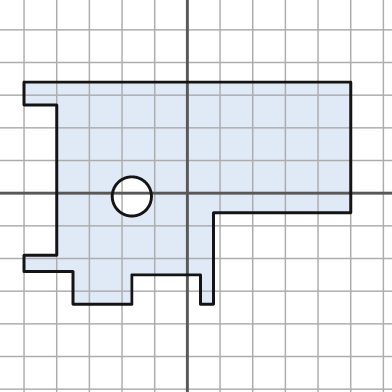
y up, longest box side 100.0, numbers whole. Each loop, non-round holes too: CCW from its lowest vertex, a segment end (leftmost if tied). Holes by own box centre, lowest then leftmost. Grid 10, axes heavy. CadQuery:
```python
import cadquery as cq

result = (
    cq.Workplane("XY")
    .moveTo(-35.0, -34.0)
    .lineTo(-17.0, -34.0)
    .lineTo(-17.0, -25.0)
    .lineTo(4.0, -25.0)
    .lineTo(4.0, -34.0)
    .lineTo(8.0, -34.0)
    .lineTo(8.0, -6.0)
    .lineTo(50.0, -6.0)
    .lineTo(50.0, 34.0)
    .lineTo(-50.0, 34.0)
    .lineTo(-50.0, 27.0)
    .lineTo(-40.0, 27.0)
    .lineTo(-40.0, -19.0)
    .lineTo(-50.0, -19.0)
    .lineTo(-50.0, -24.0)
    .lineTo(-35.0, -24.0)
    .close()
    .moveTo(-17.0, -1.0)
    .circle(6.0)
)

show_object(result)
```